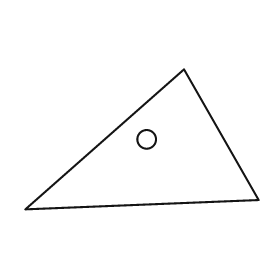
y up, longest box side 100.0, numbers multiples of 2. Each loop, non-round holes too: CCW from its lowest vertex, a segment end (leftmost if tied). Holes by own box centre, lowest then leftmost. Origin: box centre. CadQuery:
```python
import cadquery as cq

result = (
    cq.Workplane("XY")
    .moveTo(-50.0, -30.0)
    .lineTo(50.0, -26.0)
    .lineTo(18.0, 30.0)
    .close()
    .moveTo(2.0, 0.0)
    .circle(4.0)
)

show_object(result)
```